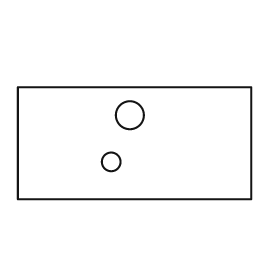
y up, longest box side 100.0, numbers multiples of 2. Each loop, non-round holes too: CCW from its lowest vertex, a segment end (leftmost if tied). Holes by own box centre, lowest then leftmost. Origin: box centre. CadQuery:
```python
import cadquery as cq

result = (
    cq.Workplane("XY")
    .moveTo(-50.0, -24.0)
    .lineTo(50.0, -24.0)
    .lineTo(50.0, 24.0)
    .lineTo(-50.0, 24.0)
    .close()
    .moveTo(-10.0, -8.0)
    .circle(4.0)
    .moveTo(-2.0, 12.0)
    .circle(6.0)
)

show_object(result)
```